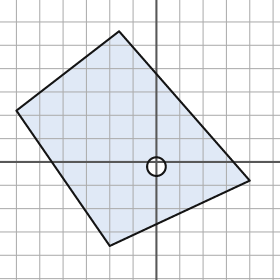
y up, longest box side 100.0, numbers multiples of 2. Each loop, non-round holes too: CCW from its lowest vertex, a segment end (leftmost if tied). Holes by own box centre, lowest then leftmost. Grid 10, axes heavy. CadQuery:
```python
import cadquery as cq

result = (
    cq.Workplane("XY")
    .moveTo(-20.0, -36.0)
    .lineTo(40.0, -8.0)
    .lineTo(-16.0, 56.0)
    .lineTo(-60.0, 22.0)
    .close()
    .moveTo(0.0, -2.0)
    .circle(4.0)
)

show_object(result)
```